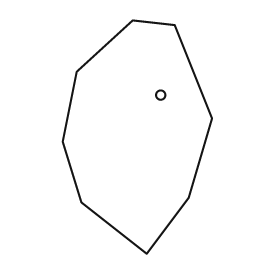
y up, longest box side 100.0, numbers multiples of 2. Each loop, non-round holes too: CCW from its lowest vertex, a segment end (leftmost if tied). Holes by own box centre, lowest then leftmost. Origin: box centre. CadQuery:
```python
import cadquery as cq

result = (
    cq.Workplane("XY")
    .moveTo(4.0, -50.0)
    .lineTo(22.0, -26.0)
    .lineTo(32.0, 8.0)
    .lineTo(16.0, 48.0)
    .lineTo(-2.0, 50.0)
    .lineTo(-26.0, 28.0)
    .lineTo(-32.0, -2.0)
    .lineTo(-24.0, -28.0)
    .close()
    .moveTo(10.0, 18.0)
    .circle(2.0)
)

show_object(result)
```